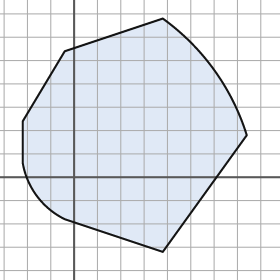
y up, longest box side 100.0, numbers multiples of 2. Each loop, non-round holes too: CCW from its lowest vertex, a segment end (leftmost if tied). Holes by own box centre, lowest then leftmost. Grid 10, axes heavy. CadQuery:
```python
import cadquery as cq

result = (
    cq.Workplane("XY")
    .moveTo(38.0, -32.0)
    .lineTo(74.0, 18.0)
    .threePointArc((60.0, 46.0), (38.0, 68.0))
    .lineTo(-4.0, 54.0)
    .lineTo(-22.0, 24.0)
    .lineTo(-22.0, 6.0)
    .threePointArc((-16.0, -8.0), (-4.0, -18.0))
    .close()
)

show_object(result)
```